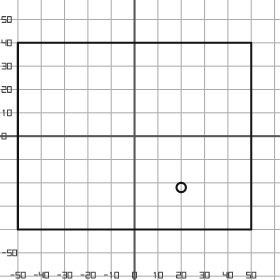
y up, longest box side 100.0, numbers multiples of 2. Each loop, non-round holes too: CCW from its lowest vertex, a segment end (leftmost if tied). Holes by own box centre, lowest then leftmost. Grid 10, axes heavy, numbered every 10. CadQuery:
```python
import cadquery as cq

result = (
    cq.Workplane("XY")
    .moveTo(-50.0, -40.0)
    .lineTo(50.0, -40.0)
    .lineTo(50.0, 40.0)
    .lineTo(-50.0, 40.0)
    .close()
    .moveTo(20.0, -22.0)
    .circle(2.0)
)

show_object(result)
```